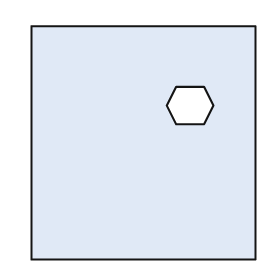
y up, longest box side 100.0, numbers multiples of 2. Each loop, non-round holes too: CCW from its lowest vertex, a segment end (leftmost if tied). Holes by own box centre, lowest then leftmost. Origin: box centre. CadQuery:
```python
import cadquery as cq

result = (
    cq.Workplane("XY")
    .moveTo(-48.0, -50.0)
    .lineTo(48.0, -50.0)
    .lineTo(48.0, 50.0)
    .lineTo(-48.0, 50.0)
    .close()
    .moveTo(14.0, 8.0)
    .lineTo(26.0, 8.0)
    .lineTo(30.0, 16.0)
    .lineTo(26.0, 24.0)
    .lineTo(14.0, 24.0)
    .lineTo(10.0, 16.0)
    .close()
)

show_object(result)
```